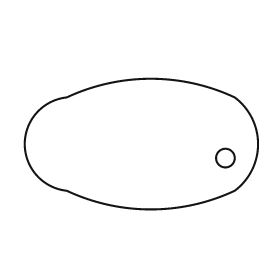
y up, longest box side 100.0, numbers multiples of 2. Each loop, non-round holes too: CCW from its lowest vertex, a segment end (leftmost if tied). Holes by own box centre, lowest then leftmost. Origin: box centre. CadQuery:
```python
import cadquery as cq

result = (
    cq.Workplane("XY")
    .moveTo(-32.0, -20.0)
    .threePointArc((4.0, -28.0), (40.0, -20.0))
    .threePointArc((50.0, 0.0), (40.0, 20.0))
    .threePointArc((4.0, 28.0), (-32.0, 20.0))
    .threePointArc((-50.0, 0.0), (-32.0, -20.0))
    .close()
    .moveTo(36.0, -6.0)
    .circle(4.0)
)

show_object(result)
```